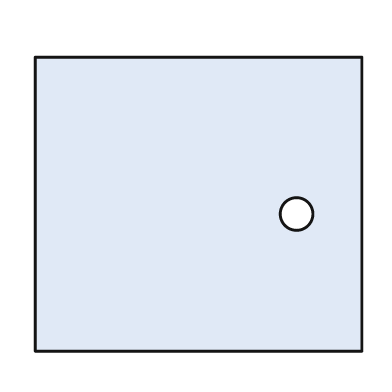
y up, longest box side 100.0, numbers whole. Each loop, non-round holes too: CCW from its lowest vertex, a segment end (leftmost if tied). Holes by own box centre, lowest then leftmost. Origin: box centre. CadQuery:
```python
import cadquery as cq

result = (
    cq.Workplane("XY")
    .moveTo(-50.0, -45.0)
    .lineTo(50.0, -45.0)
    .lineTo(50.0, 45.0)
    .lineTo(-50.0, 45.0)
    .close()
    .moveTo(30.0, -3.0)
    .circle(5.0)
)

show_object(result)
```